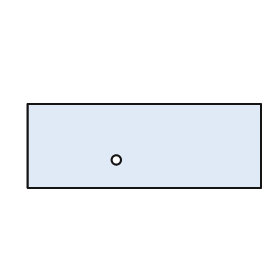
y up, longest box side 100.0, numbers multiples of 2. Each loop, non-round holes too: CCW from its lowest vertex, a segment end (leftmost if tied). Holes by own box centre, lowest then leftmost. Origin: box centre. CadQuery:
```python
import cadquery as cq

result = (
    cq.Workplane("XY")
    .moveTo(-50.0, -18.0)
    .lineTo(50.0, -18.0)
    .lineTo(50.0, 18.0)
    .lineTo(-50.0, 18.0)
    .close()
    .moveTo(-12.0, -6.0)
    .circle(2.0)
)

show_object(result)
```